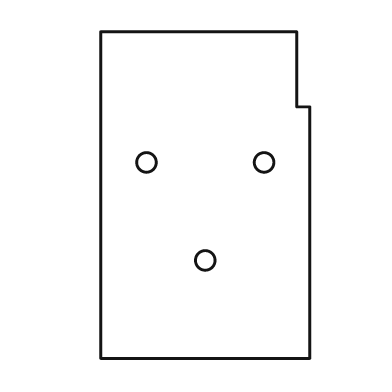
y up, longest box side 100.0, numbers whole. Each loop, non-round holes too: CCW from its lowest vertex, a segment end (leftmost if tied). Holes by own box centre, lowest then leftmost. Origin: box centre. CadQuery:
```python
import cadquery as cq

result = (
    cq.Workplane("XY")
    .moveTo(-32.0, -50.0)
    .lineTo(32.0, -50.0)
    .lineTo(32.0, 27.0)
    .lineTo(28.0, 27.0)
    .lineTo(28.0, 50.0)
    .lineTo(-32.0, 50.0)
    .close()
    .moveTo(0.0, -20.0)
    .circle(3.0)
    .moveTo(-18.0, 10.0)
    .circle(3.0)
    .moveTo(18.0, 10.0)
    .circle(3.0)
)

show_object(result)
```